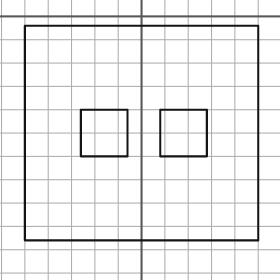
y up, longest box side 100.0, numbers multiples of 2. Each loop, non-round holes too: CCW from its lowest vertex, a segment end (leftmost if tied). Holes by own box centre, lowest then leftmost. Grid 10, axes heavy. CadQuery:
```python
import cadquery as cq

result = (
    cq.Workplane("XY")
    .moveTo(-50.0, -96.0)
    .lineTo(50.0, -96.0)
    .lineTo(50.0, -4.0)
    .lineTo(-50.0, -4.0)
    .close()
    .moveTo(-26.0, -60.0)
    .lineTo(-6.0, -60.0)
    .lineTo(-6.0, -40.0)
    .lineTo(-26.0, -40.0)
    .close()
    .moveTo(8.0, -60.0)
    .lineTo(28.0, -60.0)
    .lineTo(28.0, -40.0)
    .lineTo(8.0, -40.0)
    .close()
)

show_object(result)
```